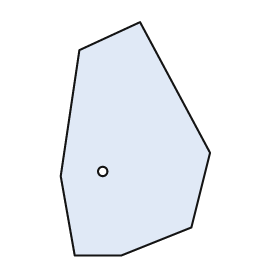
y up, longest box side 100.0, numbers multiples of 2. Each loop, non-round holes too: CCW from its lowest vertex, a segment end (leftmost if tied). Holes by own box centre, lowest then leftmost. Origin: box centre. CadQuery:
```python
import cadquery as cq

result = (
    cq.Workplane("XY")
    .moveTo(-26.0, -50.0)
    .lineTo(-6.0, -50.0)
    .lineTo(24.0, -38.0)
    .lineTo(32.0, -6.0)
    .lineTo(2.0, 50.0)
    .lineTo(-24.0, 38.0)
    .lineTo(-32.0, -16.0)
    .close()
    .moveTo(-14.0, -14.0)
    .circle(2.0)
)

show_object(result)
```